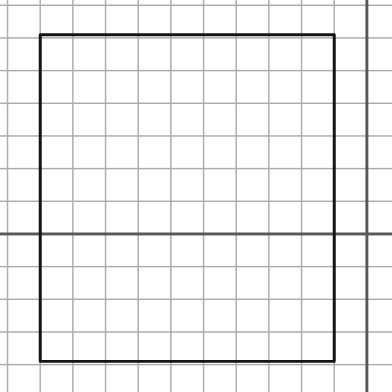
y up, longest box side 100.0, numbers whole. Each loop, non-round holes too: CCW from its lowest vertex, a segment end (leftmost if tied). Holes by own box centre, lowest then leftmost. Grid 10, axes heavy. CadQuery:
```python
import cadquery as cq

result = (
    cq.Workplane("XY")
    .moveTo(-100.0, -39.0)
    .lineTo(-10.0, -39.0)
    .lineTo(-10.0, 61.0)
    .lineTo(-100.0, 61.0)
    .close()
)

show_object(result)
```